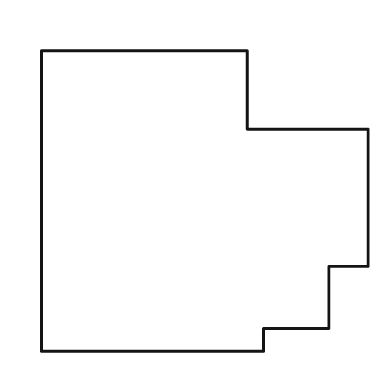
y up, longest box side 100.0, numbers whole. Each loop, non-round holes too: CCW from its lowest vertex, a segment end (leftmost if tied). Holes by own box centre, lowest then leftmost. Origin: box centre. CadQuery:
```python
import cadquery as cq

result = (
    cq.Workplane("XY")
    .moveTo(-50.0, -46.0)
    .lineTo(18.0, -46.0)
    .lineTo(18.0, -39.0)
    .lineTo(38.0, -39.0)
    .lineTo(38.0, -20.0)
    .lineTo(50.0, -20.0)
    .lineTo(50.0, 22.0)
    .lineTo(13.0, 22.0)
    .lineTo(13.0, 46.0)
    .lineTo(-50.0, 46.0)
    .close()
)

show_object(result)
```